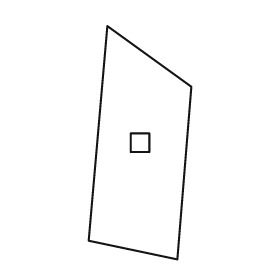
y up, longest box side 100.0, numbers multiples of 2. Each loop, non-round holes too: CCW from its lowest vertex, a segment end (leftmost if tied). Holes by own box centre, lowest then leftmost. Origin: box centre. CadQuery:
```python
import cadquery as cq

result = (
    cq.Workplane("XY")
    .moveTo(16.0, -50.0)
    .lineTo(22.0, 24.0)
    .lineTo(-14.0, 50.0)
    .lineTo(-22.0, -42.0)
    .close()
    .moveTo(-4.0, -4.0)
    .lineTo(4.0, -4.0)
    .lineTo(4.0, 4.0)
    .lineTo(-4.0, 4.0)
    .close()
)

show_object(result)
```